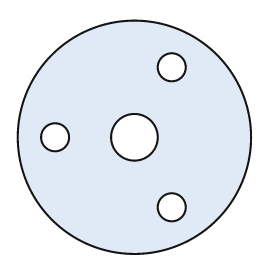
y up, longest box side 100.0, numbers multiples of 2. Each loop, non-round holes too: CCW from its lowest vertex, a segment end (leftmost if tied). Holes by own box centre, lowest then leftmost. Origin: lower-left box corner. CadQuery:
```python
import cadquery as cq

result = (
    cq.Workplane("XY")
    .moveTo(50.0, 50.0)
    .circle(50.0)
    .moveTo(66.0, 20.0)
    .circle(6.0)
    .moveTo(16.0, 50.0)
    .circle(6.0)
    .moveTo(50.0, 50.0)
    .circle(10.0)
    .moveTo(66.0, 80.0)
    .circle(6.0)
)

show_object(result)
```